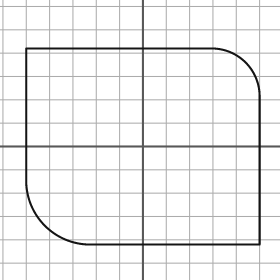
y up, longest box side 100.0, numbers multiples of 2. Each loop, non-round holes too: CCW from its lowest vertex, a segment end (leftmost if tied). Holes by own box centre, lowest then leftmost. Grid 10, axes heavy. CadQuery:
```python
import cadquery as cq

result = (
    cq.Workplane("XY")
    .moveTo(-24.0, -42.0)
    .lineTo(50.0, -42.0)
    .lineTo(50.0, 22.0)
    .threePointArc((44.0, 36.0), (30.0, 42.0))
    .lineTo(-50.0, 42.0)
    .lineTo(-50.0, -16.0)
    .threePointArc((-42.0, -34.0), (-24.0, -42.0))
    .close()
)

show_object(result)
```